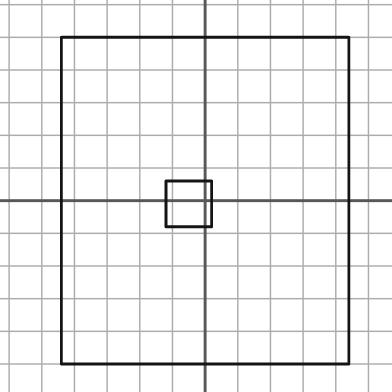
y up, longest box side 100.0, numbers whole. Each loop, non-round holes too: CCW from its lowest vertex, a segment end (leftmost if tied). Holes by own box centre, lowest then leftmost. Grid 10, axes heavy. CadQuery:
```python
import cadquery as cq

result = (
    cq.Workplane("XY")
    .moveTo(-44.0, -50.0)
    .lineTo(44.0, -50.0)
    .lineTo(44.0, 50.0)
    .lineTo(-44.0, 50.0)
    .close()
    .moveTo(-12.0, -8.0)
    .lineTo(2.0, -8.0)
    .lineTo(2.0, 6.0)
    .lineTo(-12.0, 6.0)
    .close()
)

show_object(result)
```